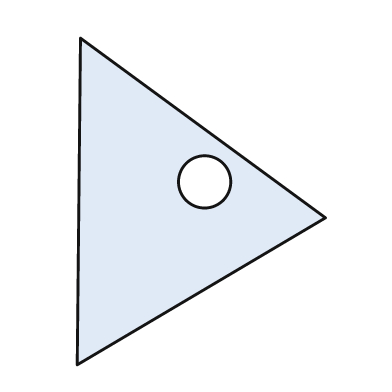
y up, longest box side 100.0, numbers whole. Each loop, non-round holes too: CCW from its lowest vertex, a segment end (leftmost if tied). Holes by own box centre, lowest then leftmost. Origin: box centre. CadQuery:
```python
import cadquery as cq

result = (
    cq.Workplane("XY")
    .moveTo(-38.0, -50.0)
    .lineTo(38.0, -5.0)
    .lineTo(-37.0, 50.0)
    .close()
    .moveTo(1.0, 6.0)
    .circle(8.0)
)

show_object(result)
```